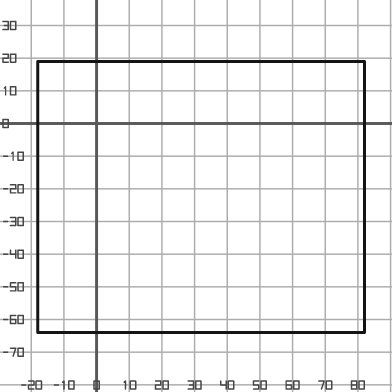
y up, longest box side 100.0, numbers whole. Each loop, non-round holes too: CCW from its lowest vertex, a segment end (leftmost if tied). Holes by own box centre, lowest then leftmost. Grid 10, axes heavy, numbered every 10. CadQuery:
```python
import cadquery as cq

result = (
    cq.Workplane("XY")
    .moveTo(-18.0, -64.0)
    .lineTo(82.0, -64.0)
    .lineTo(82.0, 19.0)
    .lineTo(-18.0, 19.0)
    .close()
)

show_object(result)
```